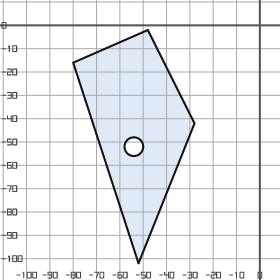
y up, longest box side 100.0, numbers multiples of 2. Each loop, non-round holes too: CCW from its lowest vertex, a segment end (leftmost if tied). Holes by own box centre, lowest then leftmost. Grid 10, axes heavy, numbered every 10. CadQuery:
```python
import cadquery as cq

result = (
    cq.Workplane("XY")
    .moveTo(-52.0, -102.0)
    .lineTo(-28.0, -42.0)
    .lineTo(-48.0, -2.0)
    .lineTo(-80.0, -16.0)
    .close()
    .moveTo(-54.0, -52.0)
    .circle(4.0)
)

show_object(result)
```